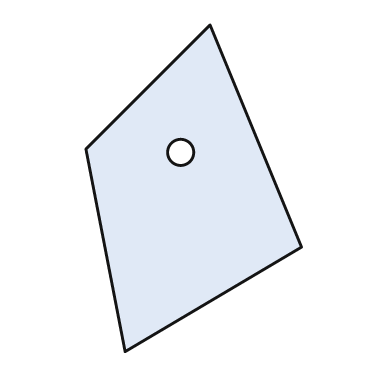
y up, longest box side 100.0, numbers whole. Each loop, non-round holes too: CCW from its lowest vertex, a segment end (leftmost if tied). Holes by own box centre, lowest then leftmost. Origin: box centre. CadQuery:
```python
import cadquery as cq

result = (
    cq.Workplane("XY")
    .moveTo(-21.0, -50.0)
    .lineTo(33.0, -18.0)
    .lineTo(5.0, 50.0)
    .lineTo(-33.0, 12.0)
    .close()
    .moveTo(-4.0, 11.0)
    .circle(4.0)
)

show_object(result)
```